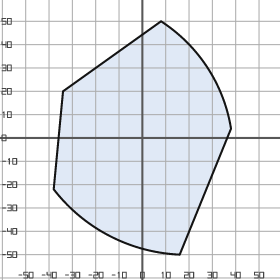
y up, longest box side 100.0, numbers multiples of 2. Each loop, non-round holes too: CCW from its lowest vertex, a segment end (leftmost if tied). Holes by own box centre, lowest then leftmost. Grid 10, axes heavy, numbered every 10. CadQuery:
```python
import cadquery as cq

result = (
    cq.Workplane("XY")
    .moveTo(16.0, -50.0)
    .lineTo(38.0, 4.0)
    .threePointArc((28.0, 30.0), (8.0, 50.0))
    .lineTo(-34.0, 20.0)
    .lineTo(-38.0, -22.0)
    .threePointArc((-14.0, -42.0), (16.0, -50.0))
    .close()
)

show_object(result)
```